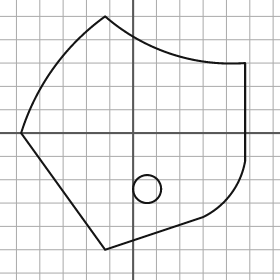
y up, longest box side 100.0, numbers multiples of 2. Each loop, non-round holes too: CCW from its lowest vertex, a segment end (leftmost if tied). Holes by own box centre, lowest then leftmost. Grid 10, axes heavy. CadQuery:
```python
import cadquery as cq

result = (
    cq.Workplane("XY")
    .moveTo(-12.0, -50.0)
    .lineTo(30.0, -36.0)
    .threePointArc((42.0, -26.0), (48.0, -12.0))
    .lineTo(48.0, 30.0)
    .threePointArc((16.0, 34.0), (-12.0, 50.0))
    .threePointArc((-34.0, 28.0), (-48.0, 0.0))
    .close()
    .moveTo(6.0, -24.0)
    .circle(6.0)
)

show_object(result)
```